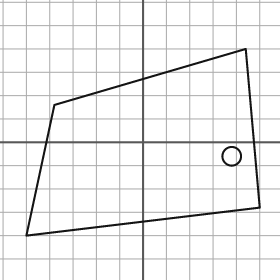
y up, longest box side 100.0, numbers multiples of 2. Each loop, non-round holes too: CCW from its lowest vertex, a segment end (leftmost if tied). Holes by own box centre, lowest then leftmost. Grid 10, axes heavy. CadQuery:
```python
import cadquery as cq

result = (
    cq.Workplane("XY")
    .moveTo(-50.0, -40.0)
    .lineTo(50.0, -28.0)
    .lineTo(44.0, 40.0)
    .lineTo(-38.0, 16.0)
    .close()
    .moveTo(38.0, -6.0)
    .circle(4.0)
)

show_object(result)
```